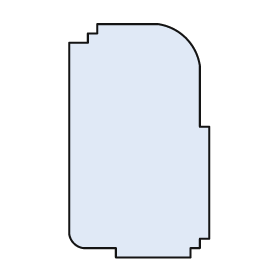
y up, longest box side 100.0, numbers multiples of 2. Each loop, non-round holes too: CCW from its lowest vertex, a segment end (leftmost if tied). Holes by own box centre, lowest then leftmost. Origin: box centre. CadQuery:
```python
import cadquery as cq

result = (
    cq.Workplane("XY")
    .moveTo(-10.0, -50.0)
    .lineTo(22.0, -50.0)
    .lineTo(22.0, -46.0)
    .lineTo(26.0, -46.0)
    .lineTo(26.0, -42.0)
    .lineTo(30.0, -42.0)
    .lineTo(30.0, 6.0)
    .lineTo(26.0, 6.0)
    .lineTo(26.0, 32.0)
    .threePointArc((20.0, 44.0), (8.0, 50.0))
    .lineTo(-18.0, 50.0)
    .lineTo(-18.0, 46.0)
    .lineTo(-22.0, 46.0)
    .lineTo(-22.0, 42.0)
    .lineTo(-30.0, 42.0)
    .lineTo(-30.0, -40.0)
    .threePointArc((-28.0, -44.0), (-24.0, -46.0))
    .lineTo(-10.0, -46.0)
    .close()
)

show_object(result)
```